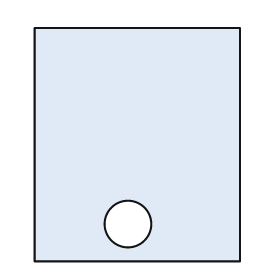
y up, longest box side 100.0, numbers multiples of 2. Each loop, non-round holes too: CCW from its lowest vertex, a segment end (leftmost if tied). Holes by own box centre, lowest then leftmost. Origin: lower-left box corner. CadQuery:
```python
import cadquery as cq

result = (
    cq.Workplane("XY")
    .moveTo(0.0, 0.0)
    .lineTo(88.0, 0.0)
    .lineTo(88.0, 100.0)
    .lineTo(0.0, 100.0)
    .close()
    .moveTo(40.0, 16.0)
    .circle(10.0)
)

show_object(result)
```